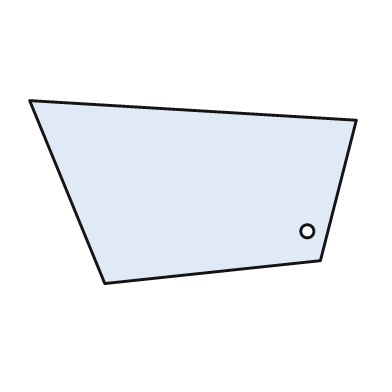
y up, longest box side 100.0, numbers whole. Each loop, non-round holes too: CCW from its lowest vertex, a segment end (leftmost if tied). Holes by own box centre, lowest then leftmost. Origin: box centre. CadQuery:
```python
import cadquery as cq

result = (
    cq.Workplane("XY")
    .moveTo(-27.0, -28.0)
    .lineTo(39.0, -21.0)
    .lineTo(50.0, 22.0)
    .lineTo(-50.0, 28.0)
    .close()
    .moveTo(35.0, -12.0)
    .circle(2.0)
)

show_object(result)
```